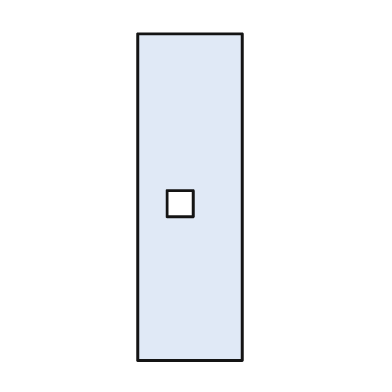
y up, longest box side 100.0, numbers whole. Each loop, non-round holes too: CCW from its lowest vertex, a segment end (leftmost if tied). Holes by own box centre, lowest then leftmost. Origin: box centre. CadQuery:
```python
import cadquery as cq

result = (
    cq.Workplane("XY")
    .moveTo(-16.0, -50.0)
    .lineTo(16.0, -50.0)
    .lineTo(16.0, 50.0)
    .lineTo(-16.0, 50.0)
    .close()
    .moveTo(-7.0, -6.0)
    .lineTo(1.0, -6.0)
    .lineTo(1.0, 2.0)
    .lineTo(-7.0, 2.0)
    .close()
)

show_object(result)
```